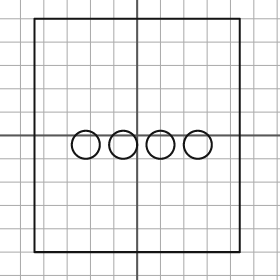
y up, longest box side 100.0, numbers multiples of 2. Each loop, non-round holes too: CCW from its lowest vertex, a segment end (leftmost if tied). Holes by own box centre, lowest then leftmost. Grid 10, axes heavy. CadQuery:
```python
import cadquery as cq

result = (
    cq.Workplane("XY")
    .moveTo(-44.0, -50.0)
    .lineTo(44.0, -50.0)
    .lineTo(44.0, 50.0)
    .lineTo(-44.0, 50.0)
    .close()
    .moveTo(-22.0, -4.0)
    .circle(6.0)
    .moveTo(-6.0, -4.0)
    .circle(6.0)
    .moveTo(10.0, -4.0)
    .circle(6.0)
    .moveTo(26.0, -4.0)
    .circle(6.0)
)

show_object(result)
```